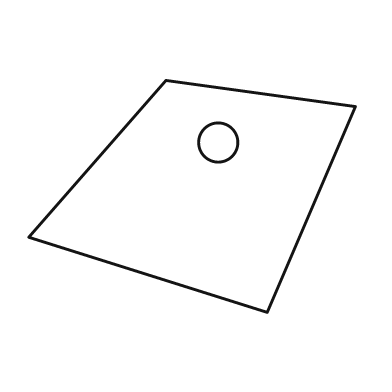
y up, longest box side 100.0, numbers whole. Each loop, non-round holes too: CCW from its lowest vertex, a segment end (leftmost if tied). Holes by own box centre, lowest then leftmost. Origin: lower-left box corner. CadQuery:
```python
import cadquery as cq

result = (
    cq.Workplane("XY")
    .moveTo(73.0, 0.0)
    .lineTo(100.0, 63.0)
    .lineTo(42.0, 71.0)
    .lineTo(0.0, 23.0)
    .close()
    .moveTo(58.0, 52.0)
    .circle(6.0)
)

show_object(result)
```